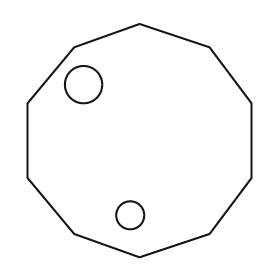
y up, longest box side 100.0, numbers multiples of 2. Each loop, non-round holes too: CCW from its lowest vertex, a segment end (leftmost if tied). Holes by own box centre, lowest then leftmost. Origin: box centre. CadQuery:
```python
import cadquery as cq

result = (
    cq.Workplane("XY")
    .moveTo(0.0, -50.0)
    .lineTo(30.0, -40.0)
    .lineTo(48.0, -16.0)
    .lineTo(48.0, 16.0)
    .lineTo(30.0, 40.0)
    .lineTo(0.0, 50.0)
    .lineTo(-28.0, 40.0)
    .lineTo(-48.0, 16.0)
    .lineTo(-48.0, -16.0)
    .lineTo(-28.0, -40.0)
    .close()
    .moveTo(-4.0, -32.0)
    .circle(6.0)
    .moveTo(-24.0, 24.0)
    .circle(8.0)
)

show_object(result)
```